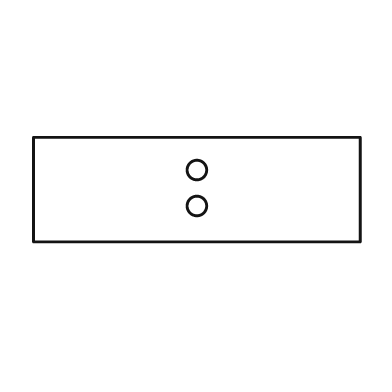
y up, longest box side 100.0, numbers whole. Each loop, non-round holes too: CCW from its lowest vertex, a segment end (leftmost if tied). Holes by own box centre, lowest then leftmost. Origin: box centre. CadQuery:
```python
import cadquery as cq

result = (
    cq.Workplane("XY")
    .moveTo(-50.0, -16.0)
    .lineTo(50.0, -16.0)
    .lineTo(50.0, 16.0)
    .lineTo(-50.0, 16.0)
    .close()
    .moveTo(0.0, -5.0)
    .circle(3.0)
    .moveTo(0.0, 6.0)
    .circle(3.0)
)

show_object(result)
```